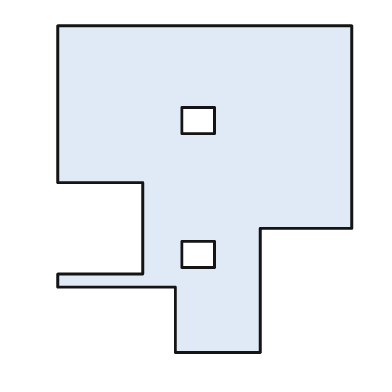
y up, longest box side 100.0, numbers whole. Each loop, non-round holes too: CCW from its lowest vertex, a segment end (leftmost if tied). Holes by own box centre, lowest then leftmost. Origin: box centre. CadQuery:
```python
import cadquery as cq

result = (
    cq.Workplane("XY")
    .moveTo(-9.0, -50.0)
    .lineTo(17.0, -50.0)
    .lineTo(17.0, -12.0)
    .lineTo(45.0, -12.0)
    .lineTo(45.0, 50.0)
    .lineTo(-45.0, 50.0)
    .lineTo(-45.0, 2.0)
    .lineTo(-19.0, 2.0)
    .lineTo(-19.0, -26.0)
    .lineTo(-45.0, -26.0)
    .lineTo(-45.0, -30.0)
    .lineTo(-9.0, -30.0)
    .close()
    .moveTo(-7.0, -24.0)
    .lineTo(3.0, -24.0)
    .lineTo(3.0, -16.0)
    .lineTo(-7.0, -16.0)
    .close()
    .moveTo(-7.0, 17.0)
    .lineTo(3.0, 17.0)
    .lineTo(3.0, 25.0)
    .lineTo(-7.0, 25.0)
    .close()
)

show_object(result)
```